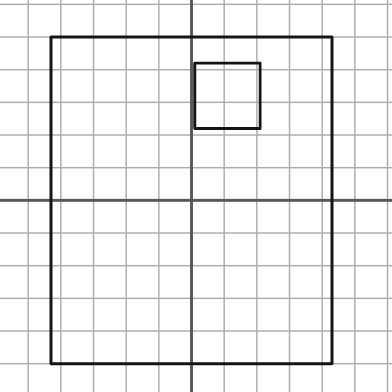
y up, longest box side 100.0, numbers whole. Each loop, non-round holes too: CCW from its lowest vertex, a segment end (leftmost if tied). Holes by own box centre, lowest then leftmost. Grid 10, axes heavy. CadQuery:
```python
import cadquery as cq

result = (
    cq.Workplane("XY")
    .moveTo(-43.0, -50.0)
    .lineTo(43.0, -50.0)
    .lineTo(43.0, 50.0)
    .lineTo(-43.0, 50.0)
    .close()
    .moveTo(1.0, 22.0)
    .lineTo(21.0, 22.0)
    .lineTo(21.0, 42.0)
    .lineTo(1.0, 42.0)
    .close()
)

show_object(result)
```